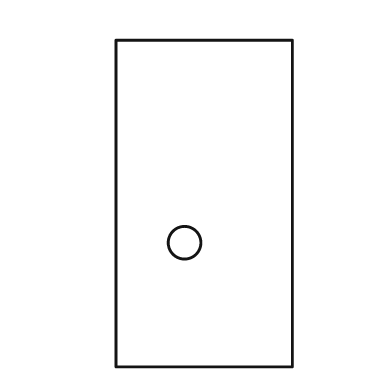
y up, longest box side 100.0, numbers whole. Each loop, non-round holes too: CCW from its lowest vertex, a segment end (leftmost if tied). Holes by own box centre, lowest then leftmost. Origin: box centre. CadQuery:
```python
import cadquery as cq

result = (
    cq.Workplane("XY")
    .moveTo(-27.0, -50.0)
    .lineTo(27.0, -50.0)
    .lineTo(27.0, 50.0)
    .lineTo(-27.0, 50.0)
    .close()
    .moveTo(-6.0, -12.0)
    .circle(5.0)
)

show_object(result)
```